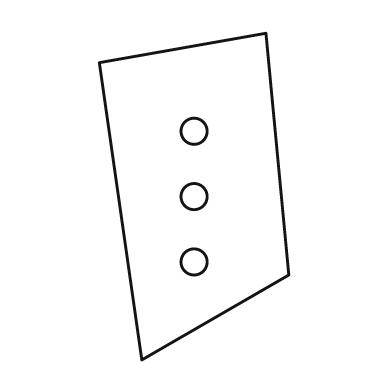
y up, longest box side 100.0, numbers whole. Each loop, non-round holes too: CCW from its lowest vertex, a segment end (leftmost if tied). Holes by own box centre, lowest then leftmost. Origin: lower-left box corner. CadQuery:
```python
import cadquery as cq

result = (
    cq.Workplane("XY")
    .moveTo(13.0, 0.0)
    .lineTo(58.0, 26.0)
    .lineTo(51.0, 100.0)
    .lineTo(0.0, 91.0)
    .close()
    .moveTo(29.0, 30.0)
    .circle(4.0)
    .moveTo(29.0, 50.0)
    .circle(4.0)
    .moveTo(29.0, 70.0)
    .circle(4.0)
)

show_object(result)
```